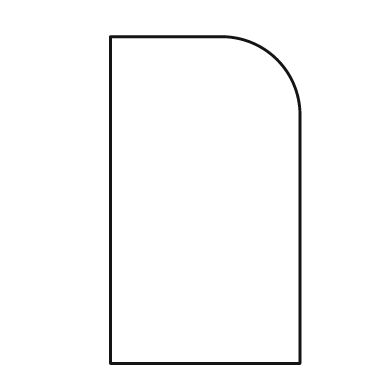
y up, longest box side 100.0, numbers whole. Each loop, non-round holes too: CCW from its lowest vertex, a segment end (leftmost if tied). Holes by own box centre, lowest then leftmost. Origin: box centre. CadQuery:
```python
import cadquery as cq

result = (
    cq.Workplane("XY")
    .moveTo(-29.0, -50.0)
    .lineTo(29.0, -50.0)
    .lineTo(29.0, 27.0)
    .threePointArc((22.0, 43.0), (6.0, 50.0))
    .lineTo(-29.0, 50.0)
    .close()
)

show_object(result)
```